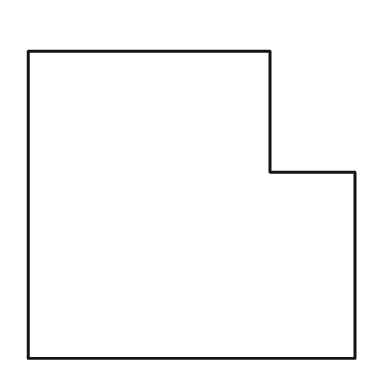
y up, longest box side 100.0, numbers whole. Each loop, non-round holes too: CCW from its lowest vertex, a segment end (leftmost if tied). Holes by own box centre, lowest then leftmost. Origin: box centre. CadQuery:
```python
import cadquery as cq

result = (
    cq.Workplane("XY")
    .moveTo(-50.0, -47.0)
    .lineTo(50.0, -47.0)
    .lineTo(50.0, 10.0)
    .lineTo(24.0, 10.0)
    .lineTo(24.0, 47.0)
    .lineTo(-50.0, 47.0)
    .close()
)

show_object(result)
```